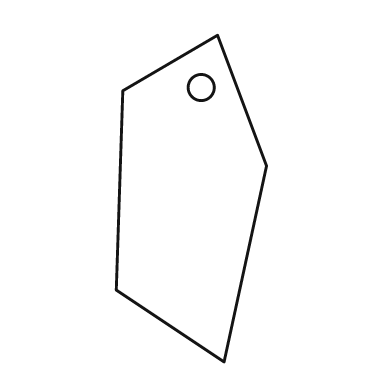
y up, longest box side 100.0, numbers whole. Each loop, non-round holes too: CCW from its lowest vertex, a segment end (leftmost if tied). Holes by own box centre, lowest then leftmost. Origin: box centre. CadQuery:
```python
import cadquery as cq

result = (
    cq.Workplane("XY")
    .moveTo(10.0, -50.0)
    .lineTo(23.0, 10.0)
    .lineTo(8.0, 50.0)
    .lineTo(-21.0, 33.0)
    .lineTo(-23.0, -28.0)
    .close()
    .moveTo(3.0, 34.0)
    .circle(4.0)
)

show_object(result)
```